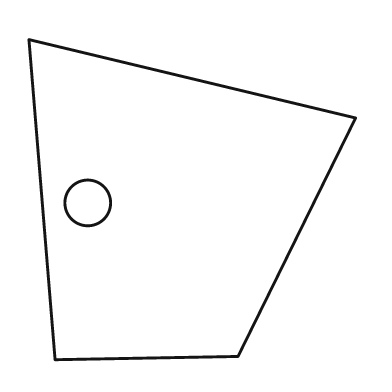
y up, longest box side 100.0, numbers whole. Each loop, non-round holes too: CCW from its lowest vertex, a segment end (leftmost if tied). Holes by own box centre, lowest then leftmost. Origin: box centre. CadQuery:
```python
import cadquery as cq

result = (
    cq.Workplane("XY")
    .moveTo(-42.0, -49.0)
    .lineTo(14.0, -48.0)
    .lineTo(50.0, 25.0)
    .lineTo(-50.0, 49.0)
    .close()
    .moveTo(-32.0, -1.0)
    .circle(7.0)
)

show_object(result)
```